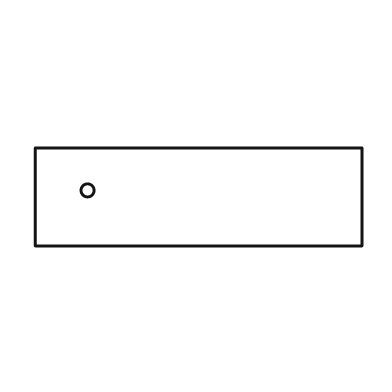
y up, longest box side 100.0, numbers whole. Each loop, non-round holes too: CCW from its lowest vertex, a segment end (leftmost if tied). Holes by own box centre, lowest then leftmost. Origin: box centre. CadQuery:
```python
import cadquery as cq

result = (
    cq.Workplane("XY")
    .moveTo(-50.0, -15.0)
    .lineTo(50.0, -15.0)
    .lineTo(50.0, 15.0)
    .lineTo(-50.0, 15.0)
    .close()
    .moveTo(-34.0, 2.0)
    .circle(2.0)
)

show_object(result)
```